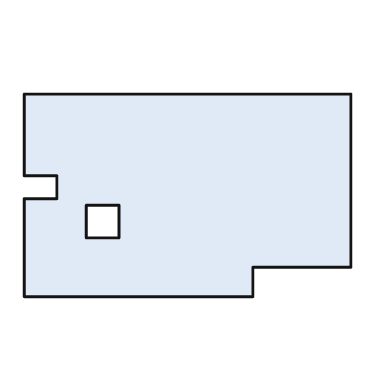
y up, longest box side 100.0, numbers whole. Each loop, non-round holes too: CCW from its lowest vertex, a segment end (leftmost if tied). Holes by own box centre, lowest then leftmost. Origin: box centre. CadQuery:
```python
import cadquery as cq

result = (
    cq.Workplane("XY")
    .moveTo(-50.0, -31.0)
    .lineTo(20.0, -31.0)
    .lineTo(20.0, -22.0)
    .lineTo(50.0, -22.0)
    .lineTo(50.0, 31.0)
    .lineTo(-50.0, 31.0)
    .lineTo(-50.0, 6.0)
    .lineTo(-40.0, 6.0)
    .lineTo(-40.0, -1.0)
    .lineTo(-50.0, -1.0)
    .close()
    .moveTo(-31.0, -13.0)
    .lineTo(-21.0, -13.0)
    .lineTo(-21.0, -3.0)
    .lineTo(-31.0, -3.0)
    .close()
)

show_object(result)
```